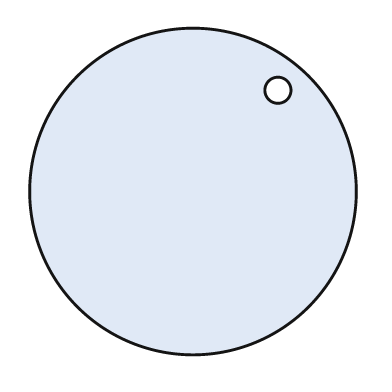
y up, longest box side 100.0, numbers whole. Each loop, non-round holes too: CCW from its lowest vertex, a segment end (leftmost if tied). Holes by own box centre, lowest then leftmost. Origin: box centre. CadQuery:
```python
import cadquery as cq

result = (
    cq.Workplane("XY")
    .moveTo(0.0, 0.0)
    .circle(50.0)
    .moveTo(26.0, 31.0)
    .circle(4.0)
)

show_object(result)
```